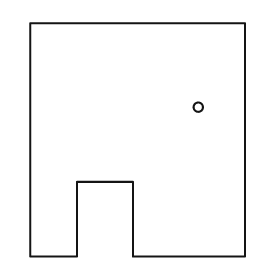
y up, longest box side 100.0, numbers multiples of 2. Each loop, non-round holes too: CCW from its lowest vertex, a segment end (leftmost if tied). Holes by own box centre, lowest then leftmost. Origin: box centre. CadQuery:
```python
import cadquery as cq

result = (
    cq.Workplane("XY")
    .moveTo(-46.0, -50.0)
    .lineTo(-26.0, -50.0)
    .lineTo(-26.0, -18.0)
    .lineTo(-2.0, -18.0)
    .lineTo(-2.0, -50.0)
    .lineTo(46.0, -50.0)
    .lineTo(46.0, 50.0)
    .lineTo(-46.0, 50.0)
    .close()
    .moveTo(26.0, 14.0)
    .circle(2.0)
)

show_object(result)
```